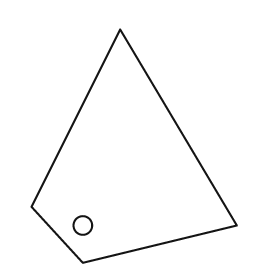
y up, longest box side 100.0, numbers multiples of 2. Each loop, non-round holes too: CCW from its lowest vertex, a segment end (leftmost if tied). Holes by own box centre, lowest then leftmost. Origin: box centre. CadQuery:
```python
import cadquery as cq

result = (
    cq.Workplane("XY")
    .moveTo(-22.0, -50.0)
    .lineTo(44.0, -34.0)
    .lineTo(-6.0, 50.0)
    .lineTo(-44.0, -26.0)
    .close()
    .moveTo(-22.0, -34.0)
    .circle(4.0)
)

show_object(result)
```